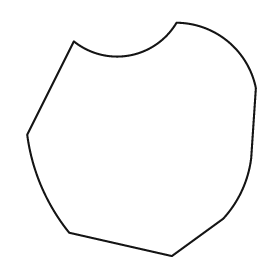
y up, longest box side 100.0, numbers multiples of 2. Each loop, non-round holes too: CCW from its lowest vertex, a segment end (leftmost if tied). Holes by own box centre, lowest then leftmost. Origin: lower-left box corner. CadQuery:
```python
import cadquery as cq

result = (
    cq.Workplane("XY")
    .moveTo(62.0, 0.0)
    .lineTo(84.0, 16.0)
    .threePointArc((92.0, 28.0), (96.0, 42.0))
    .lineTo(98.0, 72.0)
    .threePointArc((86.0, 92.0), (64.0, 100.0))
    .threePointArc((44.0, 86.0), (20.0, 92.0))
    .lineTo(0.0, 52.0)
    .threePointArc((6.0, 30.0), (18.0, 10.0))
    .close()
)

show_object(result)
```